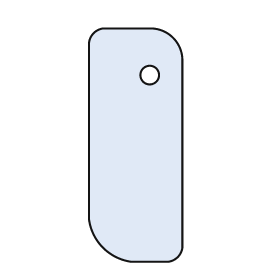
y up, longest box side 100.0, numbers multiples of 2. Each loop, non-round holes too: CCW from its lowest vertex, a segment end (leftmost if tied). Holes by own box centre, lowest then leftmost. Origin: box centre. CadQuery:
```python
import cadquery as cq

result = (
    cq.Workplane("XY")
    .moveTo(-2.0, -50.0)
    .lineTo(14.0, -50.0)
    .threePointArc((18.0, -48.0), (20.0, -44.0))
    .lineTo(20.0, 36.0)
    .threePointArc((16.0, 46.0), (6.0, 50.0))
    .lineTo(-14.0, 50.0)
    .threePointArc((-18.0, 48.0), (-20.0, 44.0))
    .lineTo(-20.0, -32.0)
    .threePointArc((-14.0, -44.0), (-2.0, -50.0))
    .close()
    .moveTo(6.0, 30.0)
    .circle(4.0)
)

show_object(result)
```